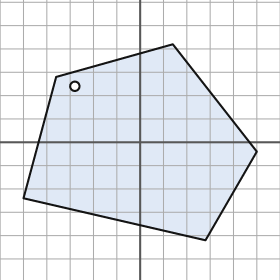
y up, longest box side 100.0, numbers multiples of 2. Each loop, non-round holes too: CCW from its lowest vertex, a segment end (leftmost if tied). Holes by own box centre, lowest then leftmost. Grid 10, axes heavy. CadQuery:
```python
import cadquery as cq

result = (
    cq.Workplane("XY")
    .moveTo(28.0, -42.0)
    .lineTo(50.0, -4.0)
    .lineTo(14.0, 42.0)
    .lineTo(-36.0, 28.0)
    .lineTo(-50.0, -24.0)
    .close()
    .moveTo(-28.0, 24.0)
    .circle(2.0)
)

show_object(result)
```